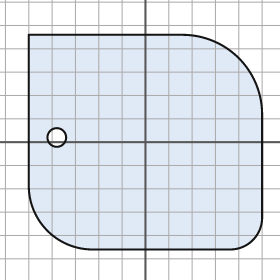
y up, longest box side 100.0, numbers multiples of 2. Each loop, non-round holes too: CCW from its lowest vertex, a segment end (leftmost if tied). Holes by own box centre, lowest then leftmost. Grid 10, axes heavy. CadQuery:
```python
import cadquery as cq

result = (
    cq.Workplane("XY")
    .moveTo(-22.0, -46.0)
    .lineTo(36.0, -46.0)
    .threePointArc((46.0, -42.0), (50.0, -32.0))
    .lineTo(50.0, 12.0)
    .threePointArc((40.0, 36.0), (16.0, 46.0))
    .lineTo(-50.0, 46.0)
    .lineTo(-50.0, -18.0)
    .threePointArc((-42.0, -38.0), (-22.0, -46.0))
    .close()
    .moveTo(-38.0, 2.0)
    .circle(4.0)
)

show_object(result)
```